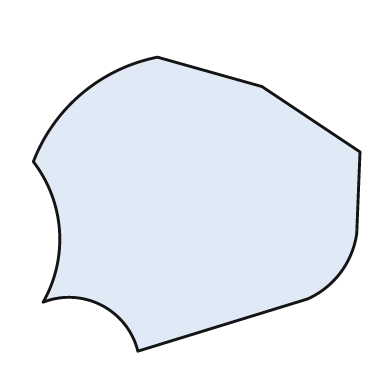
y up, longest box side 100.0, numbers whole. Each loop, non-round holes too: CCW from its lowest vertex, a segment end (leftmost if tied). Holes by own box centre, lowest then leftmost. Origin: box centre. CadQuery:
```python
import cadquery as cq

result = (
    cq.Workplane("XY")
    .moveTo(-18.0, -45.0)
    .lineTo(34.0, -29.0)
    .threePointArc((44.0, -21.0), (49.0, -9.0))
    .lineTo(50.0, 16.0)
    .lineTo(20.0, 36.0)
    .lineTo(-12.0, 45.0)
    .threePointArc((-35.0, 34.0), (-50.0, 13.0))
    .threePointArc((-42.0, -8.0), (-47.0, -30.0))
    .threePointArc((-29.0, -31.0), (-18.0, -45.0))
    .close()
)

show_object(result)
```